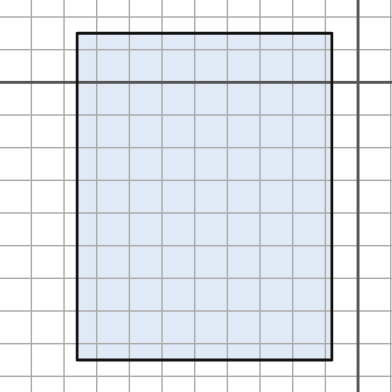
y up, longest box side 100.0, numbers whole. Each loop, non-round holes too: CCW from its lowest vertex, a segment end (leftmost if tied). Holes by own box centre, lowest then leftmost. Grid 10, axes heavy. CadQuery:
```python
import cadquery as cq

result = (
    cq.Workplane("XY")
    .moveTo(-86.0, -85.0)
    .lineTo(-8.0, -85.0)
    .lineTo(-8.0, 15.0)
    .lineTo(-86.0, 15.0)
    .close()
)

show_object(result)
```